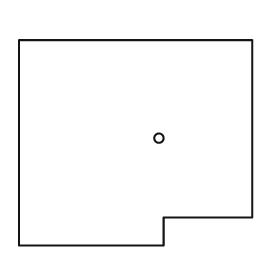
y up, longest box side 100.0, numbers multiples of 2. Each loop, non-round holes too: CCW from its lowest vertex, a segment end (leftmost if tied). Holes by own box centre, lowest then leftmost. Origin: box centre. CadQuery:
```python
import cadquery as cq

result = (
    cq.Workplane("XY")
    .moveTo(-50.0, -44.0)
    .lineTo(12.0, -44.0)
    .lineTo(12.0, -32.0)
    .lineTo(50.0, -32.0)
    .lineTo(50.0, 44.0)
    .lineTo(-50.0, 44.0)
    .close()
    .moveTo(10.0, 2.0)
    .circle(2.0)
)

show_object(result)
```